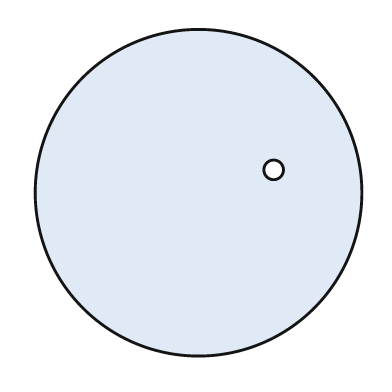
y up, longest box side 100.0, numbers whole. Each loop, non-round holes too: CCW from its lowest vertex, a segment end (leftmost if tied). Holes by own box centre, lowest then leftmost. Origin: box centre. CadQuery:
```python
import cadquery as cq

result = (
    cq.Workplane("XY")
    .moveTo(0.0, 0.0)
    .circle(50.0)
    .moveTo(23.0, 7.0)
    .circle(3.0)
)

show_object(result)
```